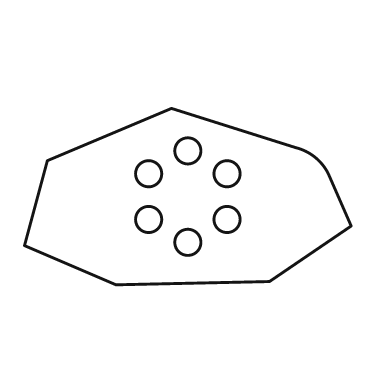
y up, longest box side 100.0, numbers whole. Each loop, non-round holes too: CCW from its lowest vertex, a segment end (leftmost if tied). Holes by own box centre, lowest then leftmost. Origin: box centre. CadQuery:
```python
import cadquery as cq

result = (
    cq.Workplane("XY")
    .moveTo(-22.0, -27.0)
    .lineTo(25.0, -26.0)
    .lineTo(50.0, -9.0)
    .lineTo(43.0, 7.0)
    .threePointArc((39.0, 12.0), (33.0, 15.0))
    .lineTo(-5.0, 27.0)
    .lineTo(-43.0, 11.0)
    .lineTo(-50.0, -15.0)
    .close()
    .moveTo(0.0, -14.0)
    .circle(4.0)
    .moveTo(-12.0, -7.0)
    .circle(4.0)
    .moveTo(12.0, -7.0)
    .circle(4.0)
    .moveTo(-12.0, 7.0)
    .circle(4.0)
    .moveTo(12.0, 7.0)
    .circle(4.0)
    .moveTo(0.0, 14.0)
    .circle(4.0)
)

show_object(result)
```